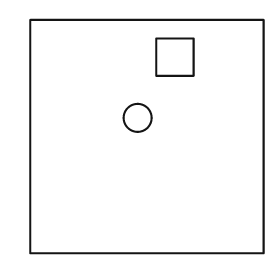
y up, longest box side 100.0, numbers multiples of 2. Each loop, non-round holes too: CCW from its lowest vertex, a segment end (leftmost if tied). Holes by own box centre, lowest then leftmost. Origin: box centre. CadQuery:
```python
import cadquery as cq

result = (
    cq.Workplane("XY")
    .moveTo(-50.0, -50.0)
    .lineTo(50.0, -50.0)
    .lineTo(50.0, 50.0)
    .lineTo(-50.0, 50.0)
    .close()
    .moveTo(-4.0, 8.0)
    .circle(6.0)
    .moveTo(4.0, 26.0)
    .lineTo(20.0, 26.0)
    .lineTo(20.0, 42.0)
    .lineTo(4.0, 42.0)
    .close()
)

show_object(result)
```